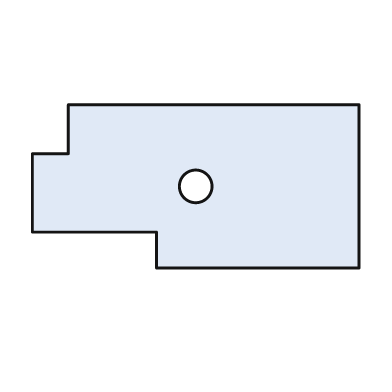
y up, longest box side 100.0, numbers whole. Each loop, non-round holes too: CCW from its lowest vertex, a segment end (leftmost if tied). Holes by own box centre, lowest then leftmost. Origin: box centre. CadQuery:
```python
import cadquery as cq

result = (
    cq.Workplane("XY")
    .moveTo(-12.0, -25.0)
    .lineTo(50.0, -25.0)
    .lineTo(50.0, 25.0)
    .lineTo(-39.0, 25.0)
    .lineTo(-39.0, 10.0)
    .lineTo(-50.0, 10.0)
    .lineTo(-50.0, -14.0)
    .lineTo(-12.0, -14.0)
    .close()
    .moveTo(0.0, 0.0)
    .circle(5.0)
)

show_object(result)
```